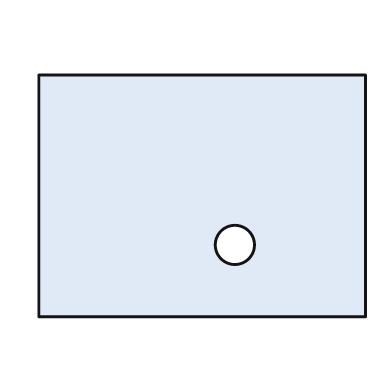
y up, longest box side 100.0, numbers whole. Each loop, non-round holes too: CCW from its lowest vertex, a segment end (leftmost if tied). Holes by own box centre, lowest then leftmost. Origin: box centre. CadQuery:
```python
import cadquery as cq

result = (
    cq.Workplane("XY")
    .moveTo(-50.0, -37.0)
    .lineTo(50.0, -37.0)
    .lineTo(50.0, 37.0)
    .lineTo(-50.0, 37.0)
    .close()
    .moveTo(10.0, -15.0)
    .circle(6.0)
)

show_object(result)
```